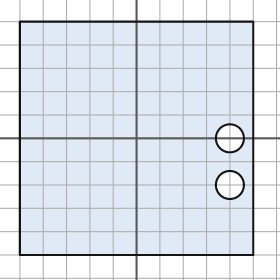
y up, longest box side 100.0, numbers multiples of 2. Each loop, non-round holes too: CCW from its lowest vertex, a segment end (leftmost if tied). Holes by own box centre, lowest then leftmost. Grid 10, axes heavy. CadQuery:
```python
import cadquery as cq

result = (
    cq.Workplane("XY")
    .moveTo(-50.0, -50.0)
    .lineTo(50.0, -50.0)
    .lineTo(50.0, 50.0)
    .lineTo(-50.0, 50.0)
    .close()
    .moveTo(40.0, -20.0)
    .circle(6.0)
    .moveTo(40.0, 0.0)
    .circle(6.0)
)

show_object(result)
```